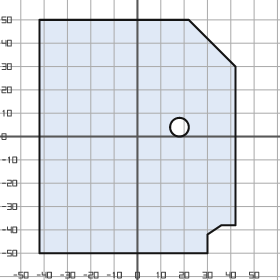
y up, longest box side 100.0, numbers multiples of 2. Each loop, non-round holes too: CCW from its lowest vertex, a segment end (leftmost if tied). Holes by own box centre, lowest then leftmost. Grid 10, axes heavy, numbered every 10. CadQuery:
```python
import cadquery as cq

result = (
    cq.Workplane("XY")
    .moveTo(-42.0, -50.0)
    .lineTo(30.0, -50.0)
    .lineTo(30.0, -42.0)
    .lineTo(36.0, -38.0)
    .lineTo(42.0, -38.0)
    .lineTo(42.0, 30.0)
    .lineTo(22.0, 50.0)
    .lineTo(-42.0, 50.0)
    .close()
    .moveTo(18.0, 4.0)
    .circle(4.0)
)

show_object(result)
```